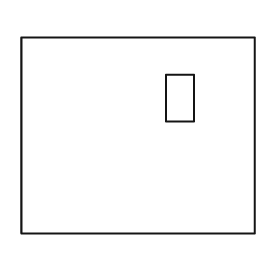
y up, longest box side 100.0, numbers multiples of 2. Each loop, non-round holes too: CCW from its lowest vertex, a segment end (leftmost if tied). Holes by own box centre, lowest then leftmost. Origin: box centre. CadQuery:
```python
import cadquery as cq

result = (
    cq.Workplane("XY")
    .moveTo(-50.0, -42.0)
    .lineTo(50.0, -42.0)
    .lineTo(50.0, 42.0)
    .lineTo(-50.0, 42.0)
    .close()
    .moveTo(12.0, 6.0)
    .lineTo(24.0, 6.0)
    .lineTo(24.0, 26.0)
    .lineTo(12.0, 26.0)
    .close()
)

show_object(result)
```